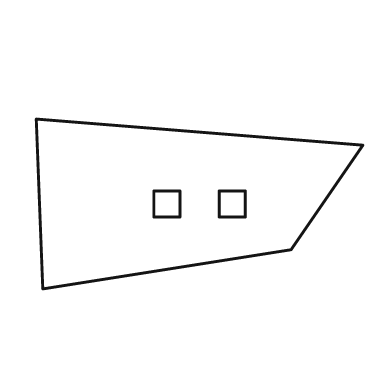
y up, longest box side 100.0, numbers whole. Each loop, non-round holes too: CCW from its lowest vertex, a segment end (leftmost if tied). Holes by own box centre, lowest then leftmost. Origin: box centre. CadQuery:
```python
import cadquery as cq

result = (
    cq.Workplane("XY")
    .moveTo(-48.0, -26.0)
    .lineTo(28.0, -14.0)
    .lineTo(50.0, 18.0)
    .lineTo(-50.0, 26.0)
    .close()
    .moveTo(-14.0, -4.0)
    .lineTo(-6.0, -4.0)
    .lineTo(-6.0, 4.0)
    .lineTo(-14.0, 4.0)
    .close()
    .moveTo(6.0, -4.0)
    .lineTo(14.0, -4.0)
    .lineTo(14.0, 4.0)
    .lineTo(6.0, 4.0)
    .close()
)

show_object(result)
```